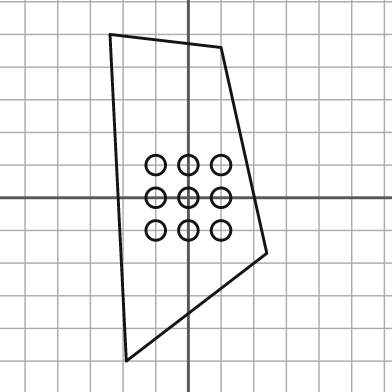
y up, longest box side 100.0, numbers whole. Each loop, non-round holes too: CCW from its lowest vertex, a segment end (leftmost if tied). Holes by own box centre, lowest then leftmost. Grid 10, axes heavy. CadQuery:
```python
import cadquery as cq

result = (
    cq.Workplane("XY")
    .moveTo(-19.0, -50.0)
    .lineTo(24.0, -17.0)
    .lineTo(10.0, 46.0)
    .lineTo(-24.0, 50.0)
    .close()
    .moveTo(-10.0, -10.0)
    .circle(3.0)
    .moveTo(0.0, -10.0)
    .circle(3.0)
    .moveTo(10.0, -10.0)
    .circle(3.0)
    .moveTo(-10.0, 0.0)
    .circle(3.0)
    .moveTo(0.0, 0.0)
    .circle(3.0)
    .moveTo(10.0, 0.0)
    .circle(3.0)
    .moveTo(-10.0, 10.0)
    .circle(3.0)
    .moveTo(0.0, 10.0)
    .circle(3.0)
    .moveTo(10.0, 10.0)
    .circle(3.0)
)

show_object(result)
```